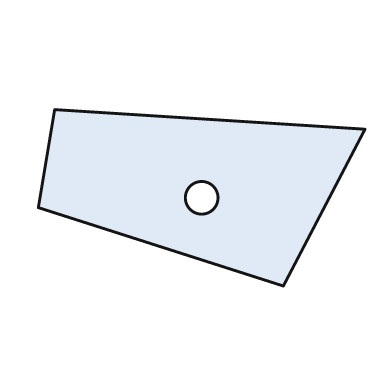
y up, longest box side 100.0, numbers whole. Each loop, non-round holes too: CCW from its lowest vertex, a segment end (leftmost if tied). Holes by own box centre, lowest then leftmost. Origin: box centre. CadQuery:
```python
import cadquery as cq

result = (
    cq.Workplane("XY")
    .moveTo(25.0, -27.0)
    .lineTo(50.0, 21.0)
    .lineTo(-45.0, 27.0)
    .lineTo(-50.0, -3.0)
    .close()
    .moveTo(0.0, 0.0)
    .circle(5.0)
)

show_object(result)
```